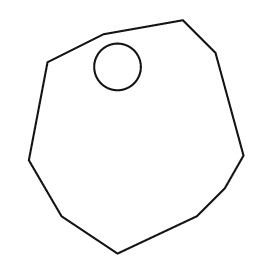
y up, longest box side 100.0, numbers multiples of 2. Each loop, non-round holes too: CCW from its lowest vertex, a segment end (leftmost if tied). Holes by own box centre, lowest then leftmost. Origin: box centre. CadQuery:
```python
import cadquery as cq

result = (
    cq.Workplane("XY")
    .moveTo(-8.0, -50.0)
    .lineTo(26.0, -34.0)
    .lineTo(38.0, -22.0)
    .lineTo(46.0, -8.0)
    .lineTo(34.0, 36.0)
    .lineTo(20.0, 50.0)
    .lineTo(-14.0, 44.0)
    .lineTo(-38.0, 32.0)
    .lineTo(-46.0, -10.0)
    .lineTo(-32.0, -34.0)
    .close()
    .moveTo(-8.0, 30.0)
    .circle(10.0)
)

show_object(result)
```